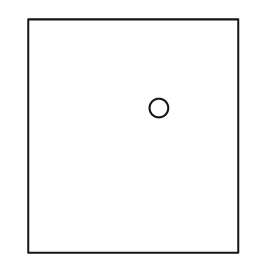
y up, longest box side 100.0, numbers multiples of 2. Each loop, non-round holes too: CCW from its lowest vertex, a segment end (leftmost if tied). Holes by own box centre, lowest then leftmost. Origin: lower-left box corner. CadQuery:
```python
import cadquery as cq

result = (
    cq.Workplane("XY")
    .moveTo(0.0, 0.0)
    .lineTo(90.0, 0.0)
    .lineTo(90.0, 100.0)
    .lineTo(0.0, 100.0)
    .close()
    .moveTo(56.0, 62.0)
    .circle(4.0)
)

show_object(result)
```